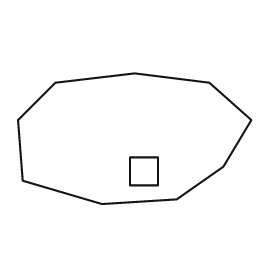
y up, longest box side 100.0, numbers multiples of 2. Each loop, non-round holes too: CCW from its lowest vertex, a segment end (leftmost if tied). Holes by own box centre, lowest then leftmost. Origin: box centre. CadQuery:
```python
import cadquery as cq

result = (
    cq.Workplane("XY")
    .moveTo(-14.0, -28.0)
    .lineTo(18.0, -26.0)
    .lineTo(38.0, -12.0)
    .lineTo(50.0, 8.0)
    .lineTo(32.0, 24.0)
    .lineTo(0.0, 28.0)
    .lineTo(-34.0, 24.0)
    .lineTo(-50.0, 8.0)
    .lineTo(-48.0, -18.0)
    .close()
    .moveTo(-2.0, -20.0)
    .lineTo(10.0, -20.0)
    .lineTo(10.0, -8.0)
    .lineTo(-2.0, -8.0)
    .close()
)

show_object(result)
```